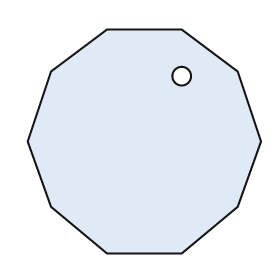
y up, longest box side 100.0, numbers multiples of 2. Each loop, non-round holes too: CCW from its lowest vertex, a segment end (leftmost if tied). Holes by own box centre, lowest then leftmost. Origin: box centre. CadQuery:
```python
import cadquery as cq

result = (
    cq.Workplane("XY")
    .moveTo(-16.0, -48.0)
    .lineTo(16.0, -48.0)
    .lineTo(40.0, -28.0)
    .lineTo(50.0, 0.0)
    .lineTo(40.0, 30.0)
    .lineTo(16.0, 48.0)
    .lineTo(-16.0, 48.0)
    .lineTo(-40.0, 30.0)
    .lineTo(-50.0, 0.0)
    .lineTo(-40.0, -28.0)
    .close()
    .moveTo(16.0, 28.0)
    .circle(4.0)
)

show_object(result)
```